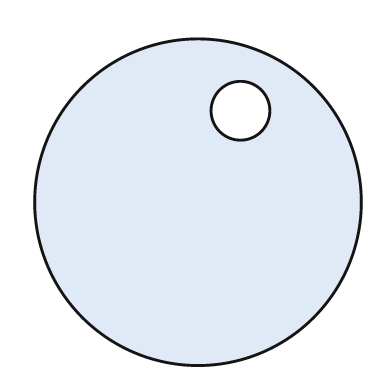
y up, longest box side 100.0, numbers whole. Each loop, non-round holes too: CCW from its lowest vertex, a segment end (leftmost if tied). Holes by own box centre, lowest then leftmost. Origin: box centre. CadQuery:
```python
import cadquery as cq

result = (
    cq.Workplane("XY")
    .moveTo(0.0, 0.0)
    .circle(50.0)
    .moveTo(13.0, 28.0)
    .circle(9.0)
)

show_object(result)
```